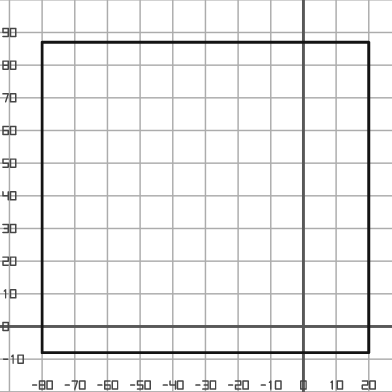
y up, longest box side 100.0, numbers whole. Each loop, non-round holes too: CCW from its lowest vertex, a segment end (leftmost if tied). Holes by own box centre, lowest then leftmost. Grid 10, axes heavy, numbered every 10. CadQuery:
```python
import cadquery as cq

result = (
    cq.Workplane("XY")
    .moveTo(-80.0, -8.0)
    .lineTo(20.0, -8.0)
    .lineTo(20.0, 87.0)
    .lineTo(-80.0, 87.0)
    .close()
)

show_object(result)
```